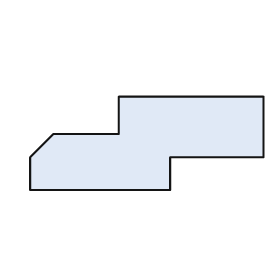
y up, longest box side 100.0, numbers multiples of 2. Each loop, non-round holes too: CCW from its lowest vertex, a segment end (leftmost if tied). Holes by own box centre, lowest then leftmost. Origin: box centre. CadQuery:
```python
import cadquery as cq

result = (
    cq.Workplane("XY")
    .moveTo(-50.0, -20.0)
    .lineTo(10.0, -20.0)
    .lineTo(10.0, -6.0)
    .lineTo(50.0, -6.0)
    .lineTo(50.0, 20.0)
    .lineTo(-12.0, 20.0)
    .lineTo(-12.0, 4.0)
    .lineTo(-40.0, 4.0)
    .lineTo(-50.0, -6.0)
    .close()
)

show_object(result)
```